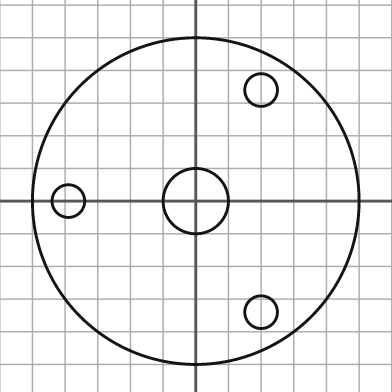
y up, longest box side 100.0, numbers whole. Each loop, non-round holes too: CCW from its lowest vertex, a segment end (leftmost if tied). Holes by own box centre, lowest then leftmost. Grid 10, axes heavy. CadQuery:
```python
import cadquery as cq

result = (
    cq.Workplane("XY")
    .moveTo(0.0, 0.0)
    .circle(50.0)
    .moveTo(20.0, -34.0)
    .circle(5.0)
    .moveTo(-39.0, 0.0)
    .circle(5.0)
    .moveTo(0.0, 0.0)
    .circle(10.0)
    .moveTo(20.0, 34.0)
    .circle(5.0)
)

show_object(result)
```